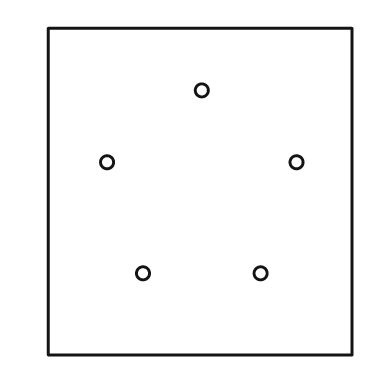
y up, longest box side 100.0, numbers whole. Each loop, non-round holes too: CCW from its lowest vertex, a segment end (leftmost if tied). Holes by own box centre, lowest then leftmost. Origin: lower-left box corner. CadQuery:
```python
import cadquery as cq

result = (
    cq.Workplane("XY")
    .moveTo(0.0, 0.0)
    .lineTo(93.0, 0.0)
    .lineTo(93.0, 100.0)
    .lineTo(0.0, 100.0)
    .close()
    .moveTo(29.0, 25.0)
    .circle(2.0)
    .moveTo(65.0, 25.0)
    .circle(2.0)
    .moveTo(18.0, 59.0)
    .circle(2.0)
    .moveTo(76.0, 59.0)
    .circle(2.0)
    .moveTo(47.0, 81.0)
    .circle(2.0)
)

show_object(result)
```